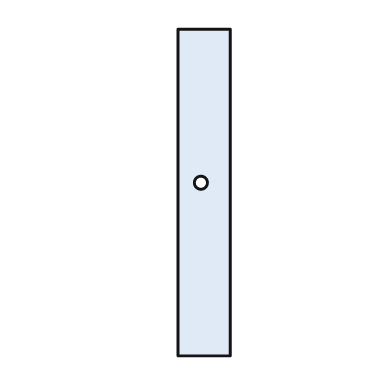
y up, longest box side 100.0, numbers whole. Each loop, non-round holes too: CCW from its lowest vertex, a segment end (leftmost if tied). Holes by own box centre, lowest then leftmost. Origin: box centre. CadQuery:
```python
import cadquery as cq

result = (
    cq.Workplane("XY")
    .moveTo(-8.0, -50.0)
    .lineTo(8.0, -50.0)
    .lineTo(8.0, 50.0)
    .lineTo(-8.0, 50.0)
    .close()
    .moveTo(-1.0, 3.0)
    .circle(2.0)
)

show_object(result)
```